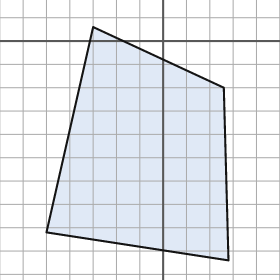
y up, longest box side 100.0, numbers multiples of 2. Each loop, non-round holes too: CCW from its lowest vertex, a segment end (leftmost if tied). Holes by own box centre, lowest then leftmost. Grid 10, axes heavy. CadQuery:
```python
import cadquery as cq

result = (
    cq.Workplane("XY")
    .moveTo(28.0, -94.0)
    .lineTo(26.0, -20.0)
    .lineTo(-30.0, 6.0)
    .lineTo(-50.0, -82.0)
    .close()
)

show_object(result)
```